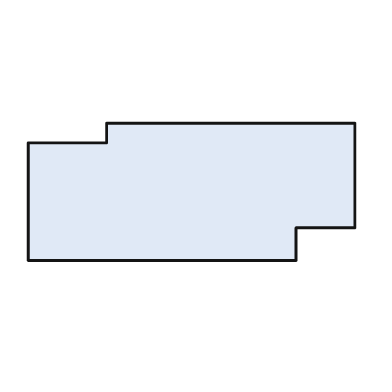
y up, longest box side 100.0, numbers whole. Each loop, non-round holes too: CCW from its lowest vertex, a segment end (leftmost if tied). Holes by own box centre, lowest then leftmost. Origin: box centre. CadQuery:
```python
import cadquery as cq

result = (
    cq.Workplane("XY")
    .moveTo(-50.0, -21.0)
    .lineTo(32.0, -21.0)
    .lineTo(32.0, -11.0)
    .lineTo(50.0, -11.0)
    .lineTo(50.0, 21.0)
    .lineTo(-26.0, 21.0)
    .lineTo(-26.0, 15.0)
    .lineTo(-50.0, 15.0)
    .close()
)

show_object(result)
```